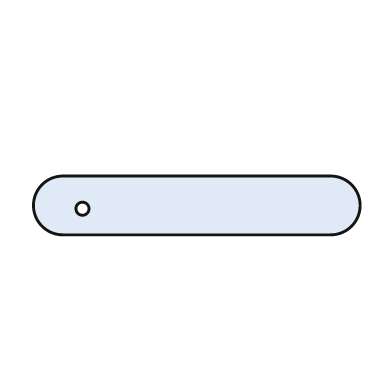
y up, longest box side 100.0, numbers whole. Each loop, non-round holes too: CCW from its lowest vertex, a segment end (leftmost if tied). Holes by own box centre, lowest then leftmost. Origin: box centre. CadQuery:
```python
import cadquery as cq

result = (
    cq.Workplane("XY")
    .moveTo(-41.0, -9.0)
    .lineTo(41.0, -9.0)
    .threePointArc((50.0, 0.0), (41.0, 9.0))
    .lineTo(-41.0, 9.0)
    .threePointArc((-50.0, 0.0), (-41.0, -9.0))
    .close()
    .moveTo(-35.0, -1.0)
    .circle(2.0)
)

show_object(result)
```